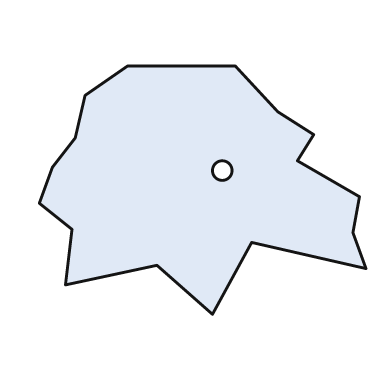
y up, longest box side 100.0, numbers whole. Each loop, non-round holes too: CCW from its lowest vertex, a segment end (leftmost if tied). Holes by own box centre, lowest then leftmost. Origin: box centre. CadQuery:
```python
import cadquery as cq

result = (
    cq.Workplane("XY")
    .moveTo(3.0, -38.0)
    .lineTo(15.0, -16.0)
    .lineTo(50.0, -24.0)
    .lineTo(46.0, -13.0)
    .lineTo(48.0, -2.0)
    .lineTo(29.0, 9.0)
    .lineTo(34.0, 17.0)
    .lineTo(23.0, 24.0)
    .lineTo(10.0, 38.0)
    .lineTo(-23.0, 38.0)
    .lineTo(-36.0, 29.0)
    .lineTo(-39.0, 16.0)
    .lineTo(-46.0, 7.0)
    .lineTo(-50.0, -4.0)
    .lineTo(-40.0, -12.0)
    .lineTo(-42.0, -29.0)
    .lineTo(-14.0, -23.0)
    .close()
    .moveTo(6.0, 6.0)
    .circle(3.0)
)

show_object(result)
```